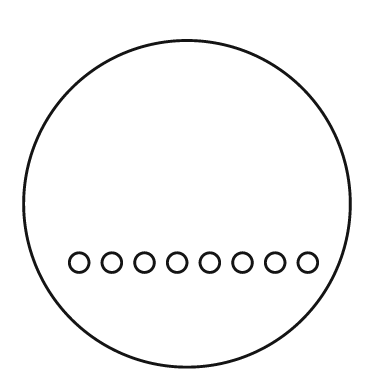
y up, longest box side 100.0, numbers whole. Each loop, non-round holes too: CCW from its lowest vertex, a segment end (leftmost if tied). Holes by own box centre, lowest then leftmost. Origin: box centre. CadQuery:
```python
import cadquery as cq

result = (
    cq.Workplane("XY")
    .moveTo(0.0, 0.0)
    .circle(50.0)
    .moveTo(-33.0, -18.0)
    .circle(3.0)
    .moveTo(-23.0, -18.0)
    .circle(3.0)
    .moveTo(-13.0, -18.0)
    .circle(3.0)
    .moveTo(-3.0, -18.0)
    .circle(3.0)
    .moveTo(7.0, -18.0)
    .circle(3.0)
    .moveTo(17.0, -18.0)
    .circle(3.0)
    .moveTo(27.0, -18.0)
    .circle(3.0)
    .moveTo(37.0, -18.0)
    .circle(3.0)
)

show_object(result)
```